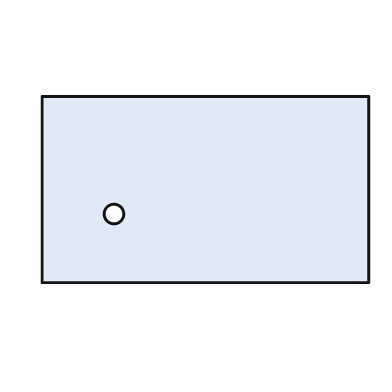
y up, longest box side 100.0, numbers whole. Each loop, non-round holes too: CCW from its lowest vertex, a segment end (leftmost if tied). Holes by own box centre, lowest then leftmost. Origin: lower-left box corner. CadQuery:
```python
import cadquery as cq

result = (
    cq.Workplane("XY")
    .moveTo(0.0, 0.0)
    .lineTo(100.0, 0.0)
    .lineTo(100.0, 57.0)
    .lineTo(0.0, 57.0)
    .close()
    .moveTo(22.0, 21.0)
    .circle(3.0)
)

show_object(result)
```